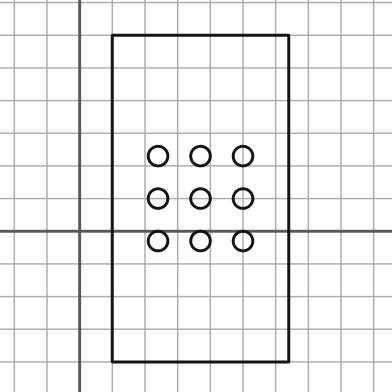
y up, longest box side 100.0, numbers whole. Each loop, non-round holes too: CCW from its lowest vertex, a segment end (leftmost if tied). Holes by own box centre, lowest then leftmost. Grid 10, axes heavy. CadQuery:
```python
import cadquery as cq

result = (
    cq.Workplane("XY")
    .moveTo(10.0, -40.0)
    .lineTo(64.0, -40.0)
    .lineTo(64.0, 60.0)
    .lineTo(10.0, 60.0)
    .close()
    .moveTo(24.0, -3.0)
    .circle(3.0)
    .moveTo(37.0, -3.0)
    .circle(3.0)
    .moveTo(50.0, -3.0)
    .circle(3.0)
    .moveTo(24.0, 10.0)
    .circle(3.0)
    .moveTo(37.0, 10.0)
    .circle(3.0)
    .moveTo(50.0, 10.0)
    .circle(3.0)
    .moveTo(24.0, 23.0)
    .circle(3.0)
    .moveTo(37.0, 23.0)
    .circle(3.0)
    .moveTo(50.0, 23.0)
    .circle(3.0)
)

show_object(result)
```